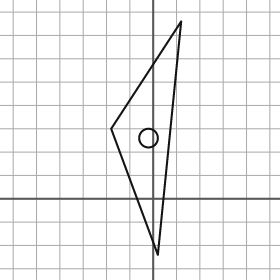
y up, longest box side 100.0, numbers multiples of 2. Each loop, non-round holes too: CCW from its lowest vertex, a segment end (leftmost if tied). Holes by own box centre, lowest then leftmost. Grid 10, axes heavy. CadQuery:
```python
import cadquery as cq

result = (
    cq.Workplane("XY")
    .moveTo(2.0, -24.0)
    .lineTo(12.0, 76.0)
    .lineTo(-18.0, 30.0)
    .close()
    .moveTo(-2.0, 26.0)
    .circle(4.0)
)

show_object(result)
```